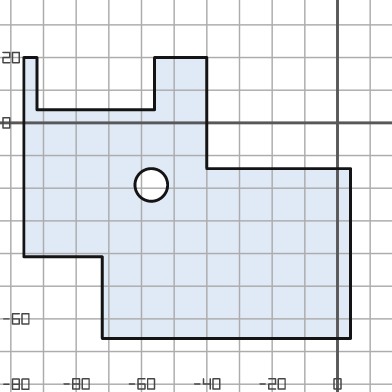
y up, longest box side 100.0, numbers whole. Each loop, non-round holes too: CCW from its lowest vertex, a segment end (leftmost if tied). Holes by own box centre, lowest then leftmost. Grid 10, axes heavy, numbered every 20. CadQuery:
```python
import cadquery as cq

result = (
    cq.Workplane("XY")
    .moveTo(-72.0, -66.0)
    .lineTo(4.0, -66.0)
    .lineTo(4.0, -14.0)
    .lineTo(-40.0, -14.0)
    .lineTo(-40.0, 20.0)
    .lineTo(-56.0, 20.0)
    .lineTo(-56.0, 4.0)
    .lineTo(-92.0, 4.0)
    .lineTo(-92.0, 20.0)
    .lineTo(-96.0, 20.0)
    .lineTo(-96.0, -41.0)
    .lineTo(-72.0, -41.0)
    .close()
    .moveTo(-57.0, -19.0)
    .circle(5.0)
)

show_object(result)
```